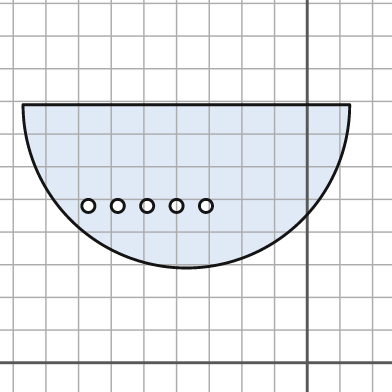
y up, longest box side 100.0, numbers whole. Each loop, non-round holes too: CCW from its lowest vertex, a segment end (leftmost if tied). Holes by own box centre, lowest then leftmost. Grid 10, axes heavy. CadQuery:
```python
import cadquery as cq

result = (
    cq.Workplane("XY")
    .moveTo(-87.0, 79.0)
    .threePointArc((-37.0, 29.0), (13.0, 79.0))
    .close()
    .moveTo(-67.0, 48.0)
    .circle(2.0)
    .moveTo(-58.0, 48.0)
    .circle(2.0)
    .moveTo(-49.0, 48.0)
    .circle(2.0)
    .moveTo(-40.0, 48.0)
    .circle(2.0)
    .moveTo(-31.0, 48.0)
    .circle(2.0)
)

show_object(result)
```